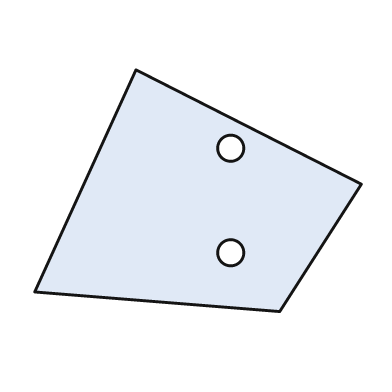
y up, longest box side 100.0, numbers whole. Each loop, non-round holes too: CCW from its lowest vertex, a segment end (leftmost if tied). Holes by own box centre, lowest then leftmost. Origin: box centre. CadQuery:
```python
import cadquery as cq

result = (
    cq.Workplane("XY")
    .moveTo(25.0, -37.0)
    .lineTo(50.0, 2.0)
    .lineTo(-19.0, 37.0)
    .lineTo(-50.0, -31.0)
    .close()
    .moveTo(10.0, -19.0)
    .circle(4.0)
    .moveTo(10.0, 13.0)
    .circle(4.0)
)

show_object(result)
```